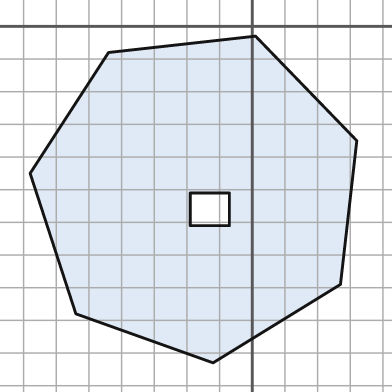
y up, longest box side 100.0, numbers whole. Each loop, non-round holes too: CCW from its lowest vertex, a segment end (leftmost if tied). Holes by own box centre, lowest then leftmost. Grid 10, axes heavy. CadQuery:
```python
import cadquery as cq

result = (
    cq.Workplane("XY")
    .moveTo(-12.0, -103.0)
    .lineTo(27.0, -79.0)
    .lineTo(32.0, -35.0)
    .lineTo(1.0, -3.0)
    .lineTo(-44.0, -8.0)
    .lineTo(-68.0, -45.0)
    .lineTo(-54.0, -88.0)
    .close()
    .moveTo(-19.0, -61.0)
    .lineTo(-7.0, -61.0)
    .lineTo(-7.0, -51.0)
    .lineTo(-19.0, -51.0)
    .close()
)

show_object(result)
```